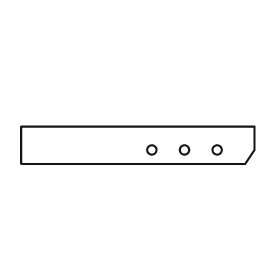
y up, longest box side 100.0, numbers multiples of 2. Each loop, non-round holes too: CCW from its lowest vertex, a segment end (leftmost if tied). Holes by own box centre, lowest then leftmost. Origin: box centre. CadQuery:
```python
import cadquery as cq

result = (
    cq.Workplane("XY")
    .moveTo(-50.0, -8.0)
    .lineTo(46.0, -8.0)
    .lineTo(50.0, -2.0)
    .lineTo(50.0, 8.0)
    .lineTo(-50.0, 8.0)
    .close()
    .moveTo(6.0, -2.0)
    .circle(2.0)
    .moveTo(20.0, -2.0)
    .circle(2.0)
    .moveTo(34.0, -2.0)
    .circle(2.0)
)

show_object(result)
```